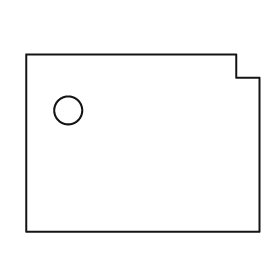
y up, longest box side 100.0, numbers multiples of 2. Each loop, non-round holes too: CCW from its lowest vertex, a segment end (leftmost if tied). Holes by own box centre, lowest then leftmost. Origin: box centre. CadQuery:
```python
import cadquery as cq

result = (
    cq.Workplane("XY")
    .moveTo(-50.0, -38.0)
    .lineTo(50.0, -38.0)
    .lineTo(50.0, 28.0)
    .lineTo(40.0, 28.0)
    .lineTo(40.0, 38.0)
    .lineTo(-50.0, 38.0)
    .close()
    .moveTo(-32.0, 14.0)
    .circle(6.0)
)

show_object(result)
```